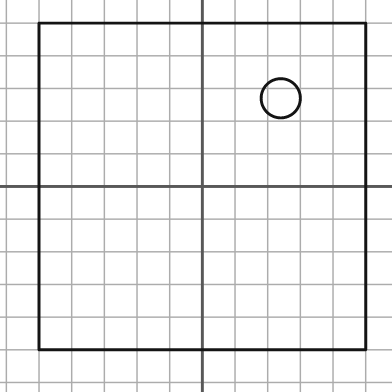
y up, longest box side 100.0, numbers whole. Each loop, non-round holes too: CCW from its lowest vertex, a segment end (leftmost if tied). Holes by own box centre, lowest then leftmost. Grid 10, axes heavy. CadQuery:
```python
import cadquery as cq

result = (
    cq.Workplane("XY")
    .moveTo(-50.0, -50.0)
    .lineTo(50.0, -50.0)
    .lineTo(50.0, 50.0)
    .lineTo(-50.0, 50.0)
    .close()
    .moveTo(24.0, 27.0)
    .circle(6.0)
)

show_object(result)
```